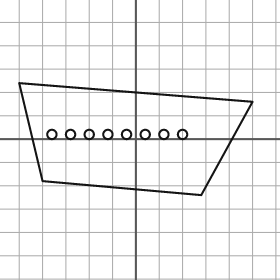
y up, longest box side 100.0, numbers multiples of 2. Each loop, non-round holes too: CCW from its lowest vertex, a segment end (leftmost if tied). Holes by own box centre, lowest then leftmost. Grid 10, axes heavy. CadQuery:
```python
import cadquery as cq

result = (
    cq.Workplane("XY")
    .moveTo(28.0, -24.0)
    .lineTo(50.0, 16.0)
    .lineTo(-50.0, 24.0)
    .lineTo(-40.0, -18.0)
    .close()
    .moveTo(-36.0, 2.0)
    .circle(2.0)
    .moveTo(-28.0, 2.0)
    .circle(2.0)
    .moveTo(-20.0, 2.0)
    .circle(2.0)
    .moveTo(-12.0, 2.0)
    .circle(2.0)
    .moveTo(-4.0, 2.0)
    .circle(2.0)
    .moveTo(4.0, 2.0)
    .circle(2.0)
    .moveTo(12.0, 2.0)
    .circle(2.0)
    .moveTo(20.0, 2.0)
    .circle(2.0)
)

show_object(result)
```